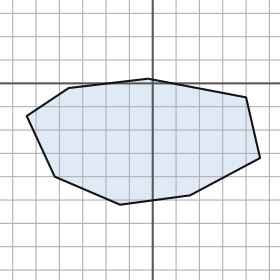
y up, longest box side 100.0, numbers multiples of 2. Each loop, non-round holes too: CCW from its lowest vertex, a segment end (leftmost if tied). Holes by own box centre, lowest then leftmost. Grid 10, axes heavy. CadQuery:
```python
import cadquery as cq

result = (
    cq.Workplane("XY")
    .moveTo(-14.0, -52.0)
    .lineTo(16.0, -48.0)
    .lineTo(46.0, -32.0)
    .lineTo(40.0, -6.0)
    .lineTo(-2.0, 2.0)
    .lineTo(-36.0, -2.0)
    .lineTo(-54.0, -14.0)
    .lineTo(-42.0, -40.0)
    .close()
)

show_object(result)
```